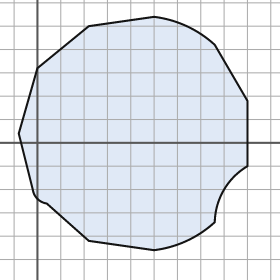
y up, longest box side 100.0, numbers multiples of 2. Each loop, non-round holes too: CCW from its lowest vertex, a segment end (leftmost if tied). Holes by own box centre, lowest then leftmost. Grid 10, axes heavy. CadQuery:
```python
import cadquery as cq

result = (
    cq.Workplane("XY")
    .moveTo(50.0, -46.0)
    .threePointArc((64.0, -42.0), (76.0, -34.0))
    .threePointArc((80.0, -20.0), (90.0, -10.0))
    .lineTo(90.0, 18.0)
    .lineTo(76.0, 42.0)
    .threePointArc((64.0, 50.0), (50.0, 54.0))
    .lineTo(22.0, 50.0)
    .lineTo(0.0, 32.0)
    .lineTo(-8.0, 4.0)
    .lineTo(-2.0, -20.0)
    .threePointArc((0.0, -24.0), (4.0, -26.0))
    .lineTo(22.0, -42.0)
    .close()
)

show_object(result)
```